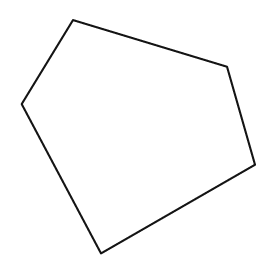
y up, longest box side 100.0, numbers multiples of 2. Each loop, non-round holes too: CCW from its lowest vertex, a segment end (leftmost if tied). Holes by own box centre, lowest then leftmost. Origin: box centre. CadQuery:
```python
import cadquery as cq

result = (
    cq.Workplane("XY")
    .moveTo(-16.0, -50.0)
    .lineTo(50.0, -12.0)
    .lineTo(38.0, 30.0)
    .lineTo(-28.0, 50.0)
    .lineTo(-50.0, 14.0)
    .close()
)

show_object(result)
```